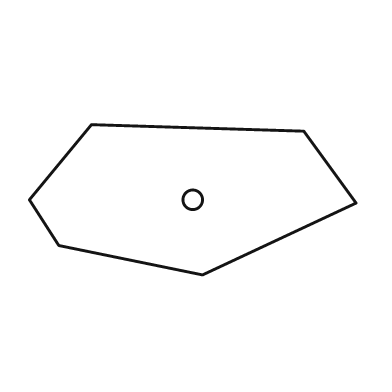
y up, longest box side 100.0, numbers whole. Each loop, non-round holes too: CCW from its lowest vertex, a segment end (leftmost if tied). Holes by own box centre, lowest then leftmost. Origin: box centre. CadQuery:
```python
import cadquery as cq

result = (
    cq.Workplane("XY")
    .moveTo(3.0, -23.0)
    .lineTo(50.0, -1.0)
    .lineTo(34.0, 21.0)
    .lineTo(-31.0, 23.0)
    .lineTo(-50.0, 0.0)
    .lineTo(-41.0, -14.0)
    .close()
    .moveTo(0.0, 0.0)
    .circle(3.0)
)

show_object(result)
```